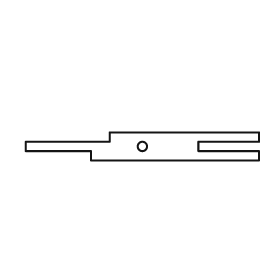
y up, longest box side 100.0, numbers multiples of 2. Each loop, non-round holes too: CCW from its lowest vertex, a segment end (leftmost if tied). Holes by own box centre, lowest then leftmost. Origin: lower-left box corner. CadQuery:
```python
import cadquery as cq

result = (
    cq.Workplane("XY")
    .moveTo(28.0, 0.0)
    .lineTo(100.0, 0.0)
    .lineTo(100.0, 4.0)
    .lineTo(74.0, 4.0)
    .lineTo(74.0, 8.0)
    .lineTo(100.0, 8.0)
    .lineTo(100.0, 12.0)
    .lineTo(36.0, 12.0)
    .lineTo(36.0, 8.0)
    .lineTo(0.0, 8.0)
    .lineTo(0.0, 4.0)
    .lineTo(28.0, 4.0)
    .close()
    .moveTo(50.0, 6.0)
    .circle(2.0)
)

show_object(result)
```